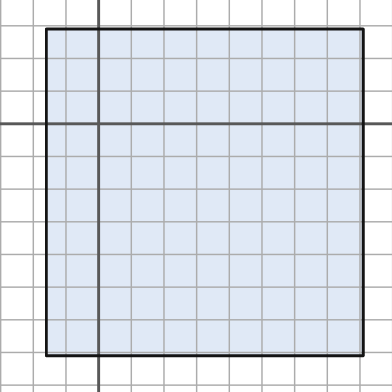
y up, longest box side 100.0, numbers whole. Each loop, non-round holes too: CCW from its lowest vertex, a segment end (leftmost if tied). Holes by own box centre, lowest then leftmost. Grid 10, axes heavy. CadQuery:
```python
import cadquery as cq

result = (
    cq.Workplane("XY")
    .moveTo(-16.0, -71.0)
    .lineTo(81.0, -71.0)
    .lineTo(81.0, 29.0)
    .lineTo(-16.0, 29.0)
    .close()
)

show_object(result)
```